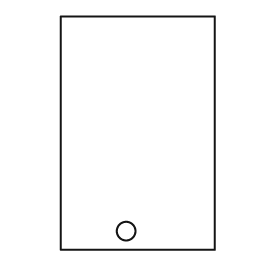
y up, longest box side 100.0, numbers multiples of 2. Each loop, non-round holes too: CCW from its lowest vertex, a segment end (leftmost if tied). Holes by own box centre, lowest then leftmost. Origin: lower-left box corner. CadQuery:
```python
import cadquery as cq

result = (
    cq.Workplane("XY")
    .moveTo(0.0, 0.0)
    .lineTo(66.0, 0.0)
    .lineTo(66.0, 100.0)
    .lineTo(0.0, 100.0)
    .close()
    .moveTo(28.0, 8.0)
    .circle(4.0)
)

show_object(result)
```